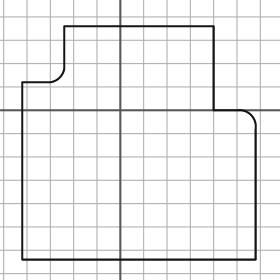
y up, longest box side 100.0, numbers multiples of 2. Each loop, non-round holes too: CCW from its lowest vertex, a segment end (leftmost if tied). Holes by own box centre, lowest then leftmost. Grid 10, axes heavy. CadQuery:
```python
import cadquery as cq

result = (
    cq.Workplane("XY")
    .moveTo(-42.0, -64.0)
    .lineTo(58.0, -64.0)
    .lineTo(58.0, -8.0)
    .threePointArc((56.0, -2.0), (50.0, 0.0))
    .lineTo(40.0, 0.0)
    .lineTo(40.0, 36.0)
    .lineTo(-24.0, 36.0)
    .lineTo(-24.0, 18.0)
    .threePointArc((-26.0, 14.0), (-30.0, 12.0))
    .lineTo(-42.0, 12.0)
    .close()
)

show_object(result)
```